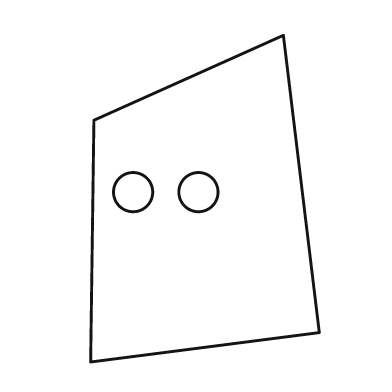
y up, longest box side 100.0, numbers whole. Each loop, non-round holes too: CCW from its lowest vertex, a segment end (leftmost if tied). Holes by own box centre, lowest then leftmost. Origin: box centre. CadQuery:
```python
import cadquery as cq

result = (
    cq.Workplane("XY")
    .moveTo(-35.0, -50.0)
    .lineTo(35.0, -41.0)
    .lineTo(24.0, 50.0)
    .lineTo(-34.0, 24.0)
    .close()
    .moveTo(-22.0, 2.0)
    .circle(6.0)
    .moveTo(-2.0, 2.0)
    .circle(6.0)
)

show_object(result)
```